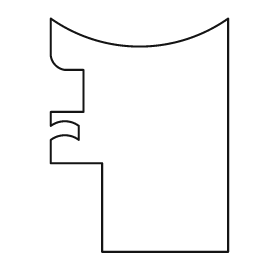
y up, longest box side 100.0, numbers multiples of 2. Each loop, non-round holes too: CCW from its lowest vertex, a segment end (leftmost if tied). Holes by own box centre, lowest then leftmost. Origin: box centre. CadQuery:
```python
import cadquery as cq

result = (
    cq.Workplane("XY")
    .moveTo(-16.0, -50.0)
    .lineTo(38.0, -50.0)
    .lineTo(38.0, 50.0)
    .threePointArc((0.0, 38.0), (-38.0, 50.0))
    .lineTo(-38.0, 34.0)
    .threePointArc((-36.0, 30.0), (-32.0, 28.0))
    .lineTo(-24.0, 28.0)
    .lineTo(-24.0, 10.0)
    .lineTo(-38.0, 10.0)
    .lineTo(-38.0, 4.0)
    .threePointArc((-32.0, 6.0), (-26.0, 4.0))
    .lineTo(-26.0, -2.0)
    .threePointArc((-32.0, 0.0), (-38.0, -2.0))
    .lineTo(-38.0, -12.0)
    .lineTo(-16.0, -12.0)
    .close()
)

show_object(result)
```